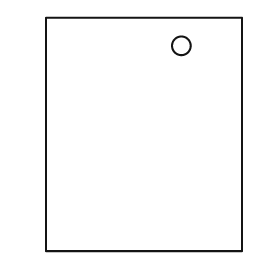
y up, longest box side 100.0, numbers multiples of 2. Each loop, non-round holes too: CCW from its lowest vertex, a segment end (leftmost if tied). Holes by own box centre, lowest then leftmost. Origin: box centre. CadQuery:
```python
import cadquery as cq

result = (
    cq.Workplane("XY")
    .moveTo(-42.0, -50.0)
    .lineTo(42.0, -50.0)
    .lineTo(42.0, 50.0)
    .lineTo(-42.0, 50.0)
    .close()
    .moveTo(16.0, 38.0)
    .circle(4.0)
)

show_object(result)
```